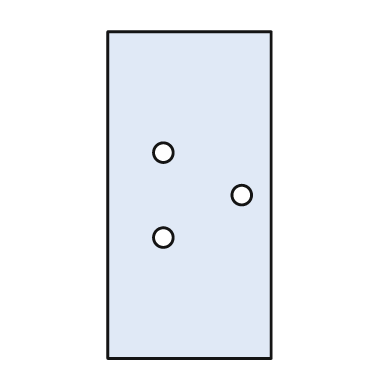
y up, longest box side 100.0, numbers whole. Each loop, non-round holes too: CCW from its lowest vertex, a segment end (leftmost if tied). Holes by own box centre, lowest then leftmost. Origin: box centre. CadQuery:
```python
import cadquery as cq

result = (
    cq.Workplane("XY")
    .moveTo(-25.0, -50.0)
    .lineTo(25.0, -50.0)
    .lineTo(25.0, 50.0)
    .lineTo(-25.0, 50.0)
    .close()
    .moveTo(-8.0, -13.0)
    .circle(3.0)
    .moveTo(16.0, 0.0)
    .circle(3.0)
    .moveTo(-8.0, 13.0)
    .circle(3.0)
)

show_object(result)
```